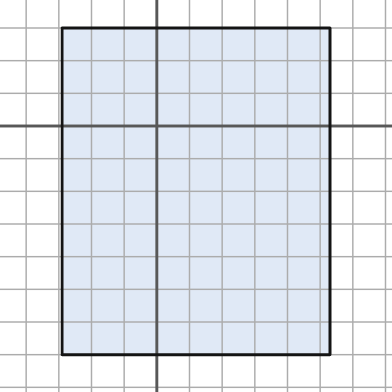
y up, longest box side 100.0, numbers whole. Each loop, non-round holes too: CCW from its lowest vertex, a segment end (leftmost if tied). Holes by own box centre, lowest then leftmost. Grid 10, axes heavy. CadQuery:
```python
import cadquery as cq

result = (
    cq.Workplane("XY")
    .moveTo(-29.0, -70.0)
    .lineTo(53.0, -70.0)
    .lineTo(53.0, 30.0)
    .lineTo(-29.0, 30.0)
    .close()
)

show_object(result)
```